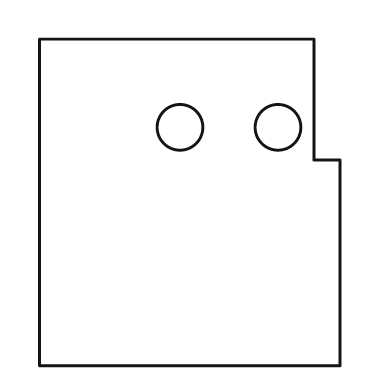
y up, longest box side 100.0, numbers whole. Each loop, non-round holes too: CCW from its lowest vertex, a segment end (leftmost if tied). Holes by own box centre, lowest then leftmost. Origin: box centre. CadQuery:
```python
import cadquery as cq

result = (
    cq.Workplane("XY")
    .moveTo(-46.0, -50.0)
    .lineTo(46.0, -50.0)
    .lineTo(46.0, 13.0)
    .lineTo(38.0, 13.0)
    .lineTo(38.0, 50.0)
    .lineTo(-46.0, 50.0)
    .close()
    .moveTo(-3.0, 23.0)
    .circle(7.0)
    .moveTo(27.0, 23.0)
    .circle(7.0)
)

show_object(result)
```